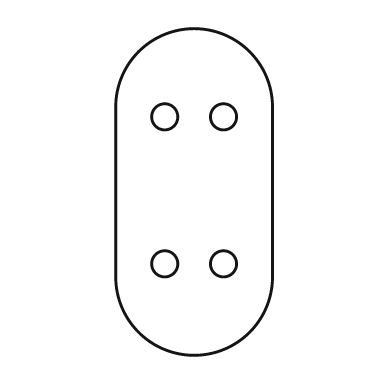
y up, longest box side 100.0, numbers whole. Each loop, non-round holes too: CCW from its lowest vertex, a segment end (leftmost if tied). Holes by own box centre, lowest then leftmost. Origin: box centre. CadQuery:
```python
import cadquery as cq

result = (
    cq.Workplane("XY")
    .moveTo(-24.0, -26.0)
    .threePointArc((0.0, -50.0), (24.0, -26.0))
    .lineTo(24.0, 26.0)
    .threePointArc((0.0, 50.0), (-24.0, 26.0))
    .close()
    .moveTo(-9.0, -22.0)
    .circle(4.0)
    .moveTo(9.0, -22.0)
    .circle(4.0)
    .moveTo(-9.0, 23.0)
    .circle(4.0)
    .moveTo(9.0, 23.0)
    .circle(4.0)
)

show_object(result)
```